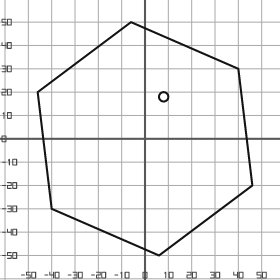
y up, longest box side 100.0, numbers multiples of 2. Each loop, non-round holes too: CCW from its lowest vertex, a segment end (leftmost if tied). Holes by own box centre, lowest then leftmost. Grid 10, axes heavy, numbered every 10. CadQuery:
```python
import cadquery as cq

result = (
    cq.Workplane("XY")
    .moveTo(6.0, -50.0)
    .lineTo(46.0, -20.0)
    .lineTo(40.0, 30.0)
    .lineTo(-6.0, 50.0)
    .lineTo(-46.0, 20.0)
    .lineTo(-40.0, -30.0)
    .close()
    .moveTo(8.0, 18.0)
    .circle(2.0)
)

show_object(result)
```